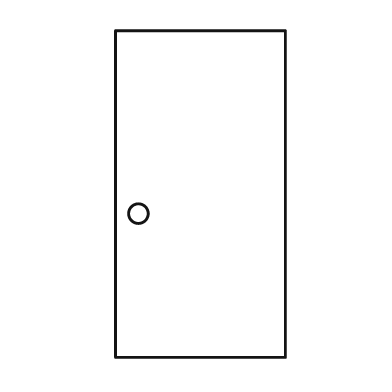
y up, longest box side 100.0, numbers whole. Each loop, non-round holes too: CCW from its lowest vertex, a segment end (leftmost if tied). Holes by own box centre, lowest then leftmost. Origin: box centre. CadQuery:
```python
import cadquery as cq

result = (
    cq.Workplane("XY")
    .moveTo(-26.0, -50.0)
    .lineTo(26.0, -50.0)
    .lineTo(26.0, 50.0)
    .lineTo(-26.0, 50.0)
    .close()
    .moveTo(-19.0, -6.0)
    .circle(3.0)
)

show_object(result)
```